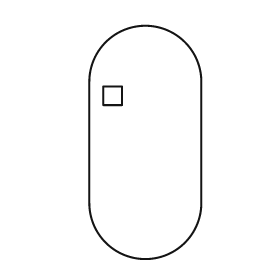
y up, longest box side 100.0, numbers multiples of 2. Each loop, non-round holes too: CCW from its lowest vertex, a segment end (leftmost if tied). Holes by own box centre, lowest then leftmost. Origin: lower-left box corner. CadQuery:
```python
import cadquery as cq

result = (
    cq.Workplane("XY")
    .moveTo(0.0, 24.0)
    .threePointArc((24.0, 0.0), (48.0, 24.0))
    .lineTo(48.0, 76.0)
    .threePointArc((24.0, 100.0), (0.0, 76.0))
    .close()
    .moveTo(6.0, 66.0)
    .lineTo(14.0, 66.0)
    .lineTo(14.0, 74.0)
    .lineTo(6.0, 74.0)
    .close()
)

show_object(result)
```